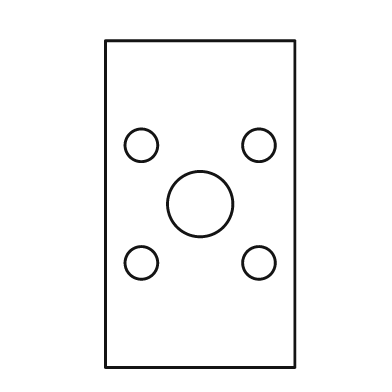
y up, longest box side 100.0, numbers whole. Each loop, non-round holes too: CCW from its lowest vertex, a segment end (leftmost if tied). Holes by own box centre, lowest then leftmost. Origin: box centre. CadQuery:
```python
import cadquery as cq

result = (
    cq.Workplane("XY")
    .moveTo(-29.0, -50.0)
    .lineTo(29.0, -50.0)
    .lineTo(29.0, 50.0)
    .lineTo(-29.0, 50.0)
    .close()
    .moveTo(-18.0, -18.0)
    .circle(5.0)
    .moveTo(18.0, -18.0)
    .circle(5.0)
    .moveTo(0.0, 0.0)
    .circle(10.0)
    .moveTo(-18.0, 18.0)
    .circle(5.0)
    .moveTo(18.0, 18.0)
    .circle(5.0)
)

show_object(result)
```